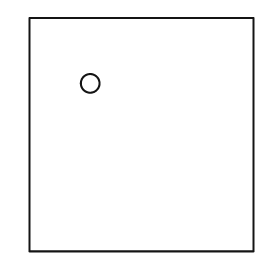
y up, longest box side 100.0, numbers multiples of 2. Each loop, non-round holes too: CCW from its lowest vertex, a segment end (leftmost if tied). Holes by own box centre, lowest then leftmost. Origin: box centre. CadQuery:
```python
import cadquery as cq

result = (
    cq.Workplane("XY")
    .moveTo(-48.0, -50.0)
    .lineTo(48.0, -50.0)
    .lineTo(48.0, 50.0)
    .lineTo(-48.0, 50.0)
    .close()
    .moveTo(-22.0, 22.0)
    .circle(4.0)
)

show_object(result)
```